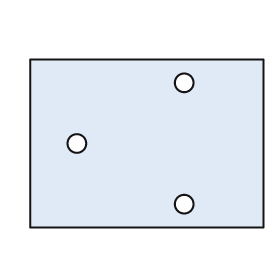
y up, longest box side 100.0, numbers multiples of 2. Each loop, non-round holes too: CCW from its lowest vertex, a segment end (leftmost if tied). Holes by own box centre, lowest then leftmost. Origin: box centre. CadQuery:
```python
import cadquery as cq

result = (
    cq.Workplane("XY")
    .moveTo(-50.0, -36.0)
    .lineTo(50.0, -36.0)
    .lineTo(50.0, 36.0)
    .lineTo(-50.0, 36.0)
    .close()
    .moveTo(16.0, -26.0)
    .circle(4.0)
    .moveTo(-30.0, 0.0)
    .circle(4.0)
    .moveTo(16.0, 26.0)
    .circle(4.0)
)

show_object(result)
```